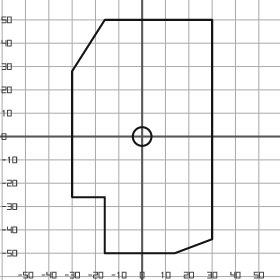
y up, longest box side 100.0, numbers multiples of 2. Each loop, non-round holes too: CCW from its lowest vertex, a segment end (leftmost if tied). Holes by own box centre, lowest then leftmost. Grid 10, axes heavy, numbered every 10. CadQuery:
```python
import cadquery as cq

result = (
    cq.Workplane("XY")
    .moveTo(-16.0, -50.0)
    .lineTo(14.0, -50.0)
    .lineTo(30.0, -44.0)
    .lineTo(30.0, 50.0)
    .lineTo(-16.0, 50.0)
    .lineTo(-30.0, 28.0)
    .lineTo(-30.0, -26.0)
    .lineTo(-16.0, -26.0)
    .close()
    .moveTo(0.0, 0.0)
    .circle(4.0)
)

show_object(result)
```